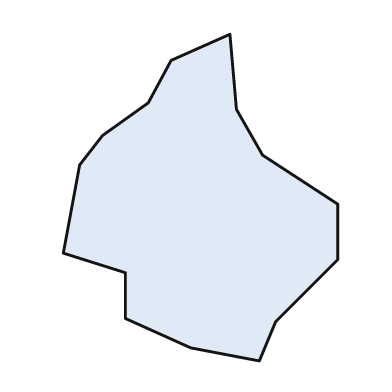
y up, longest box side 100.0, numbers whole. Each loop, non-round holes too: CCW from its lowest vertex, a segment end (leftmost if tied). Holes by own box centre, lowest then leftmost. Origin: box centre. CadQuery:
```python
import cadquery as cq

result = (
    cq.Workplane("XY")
    .moveTo(18.0, -50.0)
    .lineTo(23.0, -38.0)
    .lineTo(42.0, -19.0)
    .lineTo(42.0, -2.0)
    .lineTo(19.0, 13.0)
    .lineTo(11.0, 27.0)
    .lineTo(9.0, 50.0)
    .lineTo(-9.0, 42.0)
    .lineTo(-16.0, 29.0)
    .lineTo(-30.0, 19.0)
    .lineTo(-37.0, 10.0)
    .lineTo(-42.0, -17.0)
    .lineTo(-23.0, -23.0)
    .lineTo(-23.0, -37.0)
    .lineTo(-3.0, -46.0)
    .close()
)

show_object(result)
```